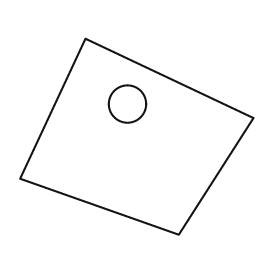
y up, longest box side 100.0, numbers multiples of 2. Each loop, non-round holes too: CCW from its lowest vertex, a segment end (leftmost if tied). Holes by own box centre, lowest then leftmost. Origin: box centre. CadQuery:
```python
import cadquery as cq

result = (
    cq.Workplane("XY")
    .moveTo(18.0, -42.0)
    .lineTo(50.0, 8.0)
    .lineTo(-22.0, 42.0)
    .lineTo(-50.0, -18.0)
    .close()
    .moveTo(-4.0, 14.0)
    .circle(8.0)
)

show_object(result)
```